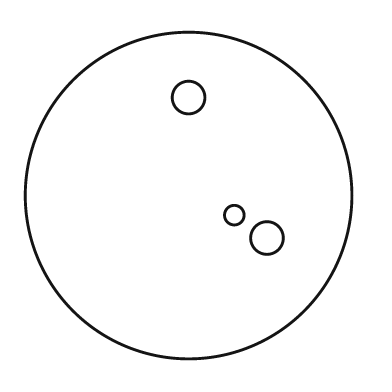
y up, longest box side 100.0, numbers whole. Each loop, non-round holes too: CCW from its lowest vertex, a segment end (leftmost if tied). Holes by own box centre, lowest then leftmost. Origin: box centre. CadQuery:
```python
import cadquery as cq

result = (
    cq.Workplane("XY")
    .moveTo(0.0, 0.0)
    .circle(50.0)
    .moveTo(24.0, -13.0)
    .circle(5.0)
    .moveTo(14.0, -6.0)
    .circle(3.0)
    .moveTo(0.0, 30.0)
    .circle(5.0)
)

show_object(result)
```